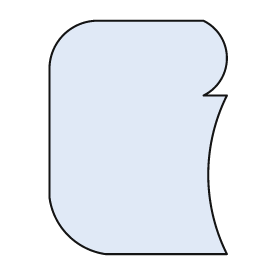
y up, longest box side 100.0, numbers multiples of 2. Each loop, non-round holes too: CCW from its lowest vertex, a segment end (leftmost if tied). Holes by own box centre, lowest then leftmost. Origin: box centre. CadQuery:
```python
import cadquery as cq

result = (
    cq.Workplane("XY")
    .moveTo(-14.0, -50.0)
    .lineTo(38.0, -50.0)
    .threePointArc((30.0, -16.0), (38.0, 18.0))
    .lineTo(28.0, 18.0)
    .threePointArc((38.0, 34.0), (28.0, 50.0))
    .lineTo(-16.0, 50.0)
    .threePointArc((-32.0, 44.0), (-38.0, 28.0))
    .lineTo(-38.0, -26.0)
    .threePointArc((-30.0, -42.0), (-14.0, -50.0))
    .close()
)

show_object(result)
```